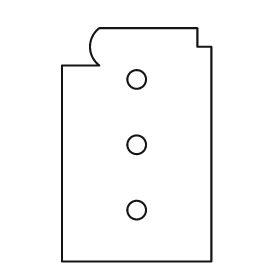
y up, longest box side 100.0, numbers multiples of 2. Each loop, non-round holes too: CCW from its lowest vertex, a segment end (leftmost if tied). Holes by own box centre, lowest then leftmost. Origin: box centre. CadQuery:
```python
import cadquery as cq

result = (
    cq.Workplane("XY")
    .moveTo(-32.0, -50.0)
    .lineTo(32.0, -50.0)
    .lineTo(32.0, 42.0)
    .lineTo(26.0, 42.0)
    .lineTo(26.0, 50.0)
    .lineTo(-16.0, 50.0)
    .threePointArc((-20.0, 42.0), (-16.0, 34.0))
    .lineTo(-32.0, 34.0)
    .close()
    .moveTo(0.0, -28.0)
    .circle(4.0)
    .moveTo(0.0, 0.0)
    .circle(4.0)
    .moveTo(0.0, 28.0)
    .circle(4.0)
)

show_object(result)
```